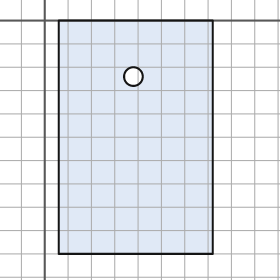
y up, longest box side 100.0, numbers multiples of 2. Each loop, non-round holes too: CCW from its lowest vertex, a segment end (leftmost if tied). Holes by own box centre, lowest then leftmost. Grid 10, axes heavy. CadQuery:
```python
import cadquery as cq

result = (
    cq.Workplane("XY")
    .moveTo(6.0, -100.0)
    .lineTo(72.0, -100.0)
    .lineTo(72.0, 0.0)
    .lineTo(6.0, 0.0)
    .close()
    .moveTo(38.0, -24.0)
    .circle(4.0)
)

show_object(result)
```